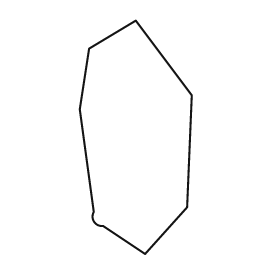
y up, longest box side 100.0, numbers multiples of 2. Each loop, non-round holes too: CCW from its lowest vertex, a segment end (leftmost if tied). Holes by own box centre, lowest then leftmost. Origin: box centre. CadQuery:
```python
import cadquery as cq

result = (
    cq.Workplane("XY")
    .moveTo(4.0, -50.0)
    .lineTo(22.0, -30.0)
    .lineTo(24.0, 18.0)
    .lineTo(0.0, 50.0)
    .lineTo(-20.0, 38.0)
    .lineTo(-24.0, 12.0)
    .lineTo(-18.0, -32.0)
    .threePointArc((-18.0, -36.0), (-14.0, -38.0))
    .close()
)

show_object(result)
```